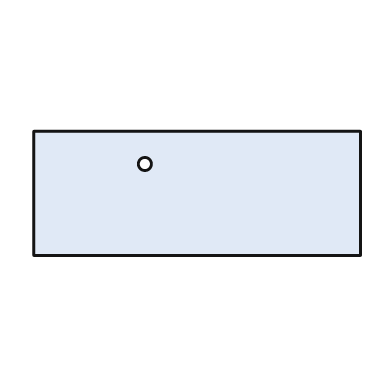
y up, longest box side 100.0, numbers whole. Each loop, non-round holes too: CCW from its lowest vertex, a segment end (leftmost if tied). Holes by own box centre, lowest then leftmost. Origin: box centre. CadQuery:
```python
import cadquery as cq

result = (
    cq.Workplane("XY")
    .moveTo(-50.0, -19.0)
    .lineTo(50.0, -19.0)
    .lineTo(50.0, 19.0)
    .lineTo(-50.0, 19.0)
    .close()
    .moveTo(-16.0, 9.0)
    .circle(2.0)
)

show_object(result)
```